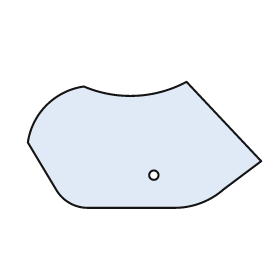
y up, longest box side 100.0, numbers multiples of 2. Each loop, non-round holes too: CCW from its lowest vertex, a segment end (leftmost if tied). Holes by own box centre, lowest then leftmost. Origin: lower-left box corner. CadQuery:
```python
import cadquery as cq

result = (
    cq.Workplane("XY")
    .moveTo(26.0, 0.0)
    .lineTo(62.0, 0.0)
    .threePointArc((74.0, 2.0), (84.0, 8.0))
    .lineTo(100.0, 20.0)
    .lineTo(68.0, 54.0)
    .threePointArc((46.0, 48.0), (24.0, 52.0))
    .threePointArc((8.0, 44.0), (0.0, 28.0))
    .lineTo(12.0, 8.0)
    .threePointArc((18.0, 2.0), (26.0, 0.0))
    .close()
    .moveTo(54.0, 14.0)
    .circle(2.0)
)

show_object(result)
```